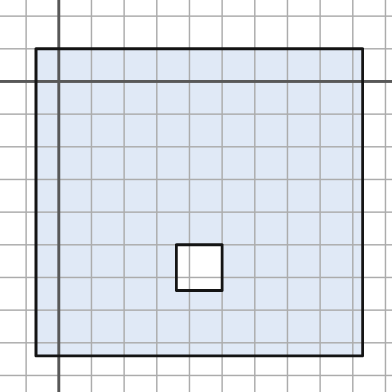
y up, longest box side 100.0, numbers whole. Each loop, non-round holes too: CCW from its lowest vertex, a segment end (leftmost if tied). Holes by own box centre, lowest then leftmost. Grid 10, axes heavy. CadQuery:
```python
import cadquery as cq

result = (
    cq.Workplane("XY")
    .moveTo(-7.0, -84.0)
    .lineTo(93.0, -84.0)
    .lineTo(93.0, 10.0)
    .lineTo(-7.0, 10.0)
    .close()
    .moveTo(36.0, -64.0)
    .lineTo(50.0, -64.0)
    .lineTo(50.0, -50.0)
    .lineTo(36.0, -50.0)
    .close()
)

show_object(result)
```